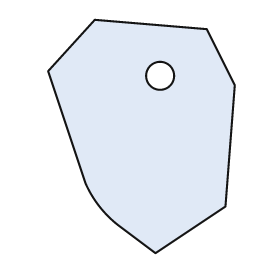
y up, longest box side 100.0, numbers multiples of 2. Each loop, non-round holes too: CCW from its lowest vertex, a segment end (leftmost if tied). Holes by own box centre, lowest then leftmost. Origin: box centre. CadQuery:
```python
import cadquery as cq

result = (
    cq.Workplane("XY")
    .moveTo(6.0, -50.0)
    .lineTo(36.0, -30.0)
    .lineTo(40.0, 22.0)
    .lineTo(28.0, 46.0)
    .lineTo(-20.0, 50.0)
    .lineTo(-40.0, 28.0)
    .lineTo(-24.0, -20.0)
    .threePointArc((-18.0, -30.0), (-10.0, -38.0))
    .close()
    .moveTo(8.0, 26.0)
    .circle(6.0)
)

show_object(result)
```